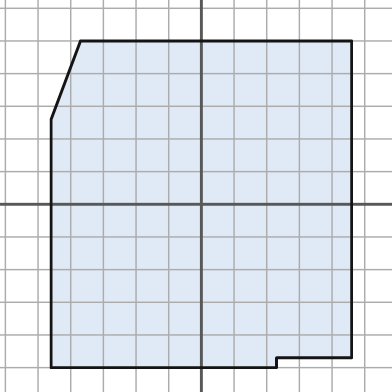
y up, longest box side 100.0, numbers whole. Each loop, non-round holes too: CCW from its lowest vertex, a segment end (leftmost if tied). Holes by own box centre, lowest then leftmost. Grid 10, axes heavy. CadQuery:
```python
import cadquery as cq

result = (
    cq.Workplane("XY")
    .moveTo(-46.0, -50.0)
    .lineTo(23.0, -50.0)
    .lineTo(23.0, -47.0)
    .lineTo(46.0, -47.0)
    .lineTo(46.0, 50.0)
    .lineTo(-37.0, 50.0)
    .lineTo(-46.0, 26.0)
    .close()
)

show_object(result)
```